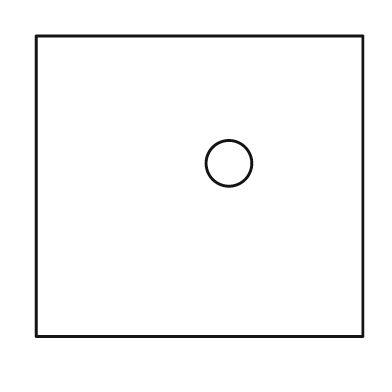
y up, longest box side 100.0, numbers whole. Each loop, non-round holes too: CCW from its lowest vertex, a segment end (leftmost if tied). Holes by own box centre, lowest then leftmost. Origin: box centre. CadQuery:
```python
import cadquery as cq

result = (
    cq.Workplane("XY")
    .moveTo(-50.0, -46.0)
    .lineTo(50.0, -46.0)
    .lineTo(50.0, 46.0)
    .lineTo(-50.0, 46.0)
    .close()
    .moveTo(9.0, 7.0)
    .circle(7.0)
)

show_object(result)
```